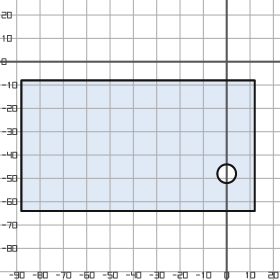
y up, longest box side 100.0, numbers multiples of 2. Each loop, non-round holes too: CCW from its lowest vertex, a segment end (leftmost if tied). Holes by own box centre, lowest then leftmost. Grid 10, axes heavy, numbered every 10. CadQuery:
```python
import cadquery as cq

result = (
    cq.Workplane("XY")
    .moveTo(-88.0, -64.0)
    .lineTo(12.0, -64.0)
    .lineTo(12.0, -8.0)
    .lineTo(-88.0, -8.0)
    .close()
    .moveTo(0.0, -48.0)
    .circle(4.0)
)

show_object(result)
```